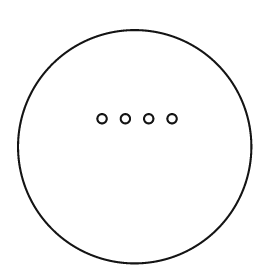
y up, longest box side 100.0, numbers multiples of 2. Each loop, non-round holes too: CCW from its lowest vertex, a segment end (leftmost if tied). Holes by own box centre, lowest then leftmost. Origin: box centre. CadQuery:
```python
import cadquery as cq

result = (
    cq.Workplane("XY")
    .moveTo(0.0, 0.0)
    .circle(50.0)
    .moveTo(-14.0, 12.0)
    .circle(2.0)
    .moveTo(-4.0, 12.0)
    .circle(2.0)
    .moveTo(6.0, 12.0)
    .circle(2.0)
    .moveTo(16.0, 12.0)
    .circle(2.0)
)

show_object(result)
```